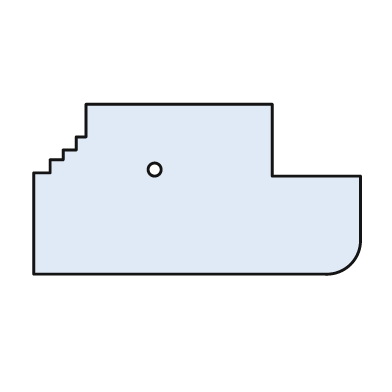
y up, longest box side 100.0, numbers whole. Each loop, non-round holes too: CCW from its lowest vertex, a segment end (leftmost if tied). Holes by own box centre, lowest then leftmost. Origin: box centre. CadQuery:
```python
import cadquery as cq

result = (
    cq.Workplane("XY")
    .moveTo(-50.0, -26.0)
    .lineTo(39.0, -26.0)
    .threePointArc((47.0, -23.0), (50.0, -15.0))
    .lineTo(50.0, 4.0)
    .lineTo(23.0, 4.0)
    .lineTo(23.0, 26.0)
    .lineTo(-34.0, 26.0)
    .lineTo(-34.0, 16.0)
    .lineTo(-37.0, 16.0)
    .lineTo(-37.0, 12.0)
    .lineTo(-41.0, 12.0)
    .lineTo(-41.0, 9.0)
    .lineTo(-45.0, 9.0)
    .lineTo(-45.0, 5.0)
    .lineTo(-50.0, 5.0)
    .close()
    .moveTo(-13.0, 6.0)
    .circle(2.0)
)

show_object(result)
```